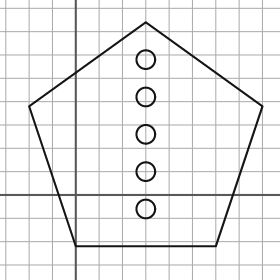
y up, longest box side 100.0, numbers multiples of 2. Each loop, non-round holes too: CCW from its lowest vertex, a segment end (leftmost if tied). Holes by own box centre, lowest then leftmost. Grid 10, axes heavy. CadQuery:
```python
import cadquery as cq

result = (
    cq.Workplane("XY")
    .moveTo(0.0, -22.0)
    .lineTo(60.0, -22.0)
    .lineTo(80.0, 38.0)
    .lineTo(30.0, 74.0)
    .lineTo(-20.0, 38.0)
    .close()
    .moveTo(30.0, -6.0)
    .circle(4.0)
    .moveTo(30.0, 10.0)
    .circle(4.0)
    .moveTo(30.0, 26.0)
    .circle(4.0)
    .moveTo(30.0, 42.0)
    .circle(4.0)
    .moveTo(30.0, 58.0)
    .circle(4.0)
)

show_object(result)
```